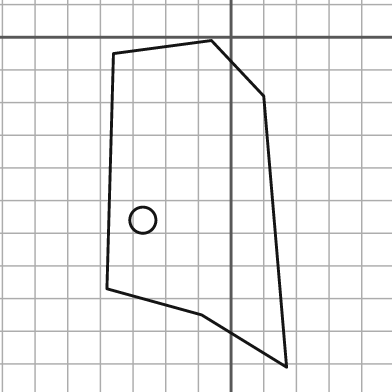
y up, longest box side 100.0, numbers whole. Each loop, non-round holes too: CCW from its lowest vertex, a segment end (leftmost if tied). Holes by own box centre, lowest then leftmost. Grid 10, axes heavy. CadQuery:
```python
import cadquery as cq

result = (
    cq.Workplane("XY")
    .moveTo(17.0, -101.0)
    .lineTo(10.0, -18.0)
    .lineTo(-6.0, -1.0)
    .lineTo(-36.0, -5.0)
    .lineTo(-38.0, -77.0)
    .lineTo(-9.0, -85.0)
    .close()
    .moveTo(-27.0, -56.0)
    .circle(4.0)
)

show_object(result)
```